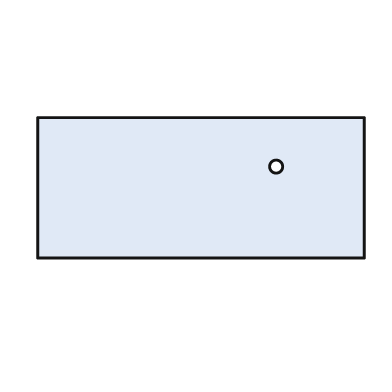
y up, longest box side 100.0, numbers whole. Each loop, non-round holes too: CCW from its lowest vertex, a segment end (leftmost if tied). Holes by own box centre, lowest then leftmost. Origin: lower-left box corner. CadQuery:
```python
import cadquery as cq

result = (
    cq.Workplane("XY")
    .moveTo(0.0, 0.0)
    .lineTo(100.0, 0.0)
    .lineTo(100.0, 43.0)
    .lineTo(0.0, 43.0)
    .close()
    .moveTo(73.0, 28.0)
    .circle(2.0)
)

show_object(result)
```